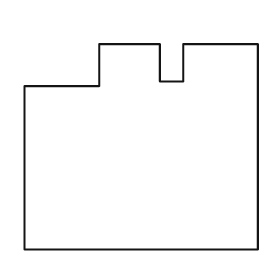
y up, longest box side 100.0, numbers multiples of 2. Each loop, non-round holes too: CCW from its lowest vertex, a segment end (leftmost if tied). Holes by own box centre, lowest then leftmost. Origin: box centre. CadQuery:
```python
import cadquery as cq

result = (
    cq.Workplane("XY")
    .moveTo(-50.0, -44.0)
    .lineTo(50.0, -44.0)
    .lineTo(50.0, 44.0)
    .lineTo(18.0, 44.0)
    .lineTo(18.0, 28.0)
    .lineTo(8.0, 28.0)
    .lineTo(8.0, 44.0)
    .lineTo(-18.0, 44.0)
    .lineTo(-18.0, 26.0)
    .lineTo(-50.0, 26.0)
    .close()
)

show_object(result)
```